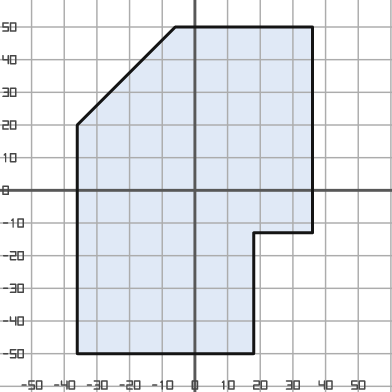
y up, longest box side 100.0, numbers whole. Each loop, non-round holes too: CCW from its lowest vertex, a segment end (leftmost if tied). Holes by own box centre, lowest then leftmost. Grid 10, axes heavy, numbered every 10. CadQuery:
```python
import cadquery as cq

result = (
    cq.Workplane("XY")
    .moveTo(-36.0, -50.0)
    .lineTo(18.0, -50.0)
    .lineTo(18.0, -13.0)
    .lineTo(36.0, -13.0)
    .lineTo(36.0, 50.0)
    .lineTo(-6.0, 50.0)
    .lineTo(-36.0, 20.0)
    .close()
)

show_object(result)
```